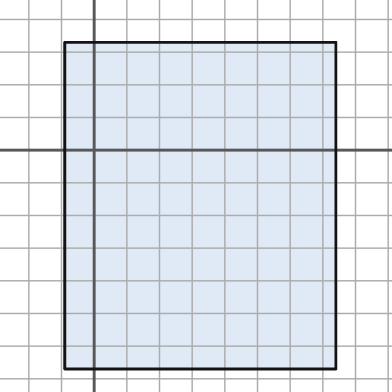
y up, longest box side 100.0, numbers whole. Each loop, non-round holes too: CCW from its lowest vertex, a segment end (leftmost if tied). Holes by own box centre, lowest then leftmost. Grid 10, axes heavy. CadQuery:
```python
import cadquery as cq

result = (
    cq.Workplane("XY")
    .moveTo(-9.0, -67.0)
    .lineTo(74.0, -67.0)
    .lineTo(74.0, 33.0)
    .lineTo(-9.0, 33.0)
    .close()
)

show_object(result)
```